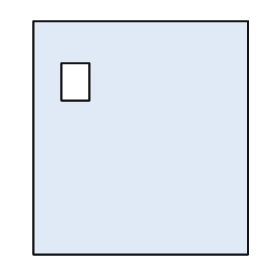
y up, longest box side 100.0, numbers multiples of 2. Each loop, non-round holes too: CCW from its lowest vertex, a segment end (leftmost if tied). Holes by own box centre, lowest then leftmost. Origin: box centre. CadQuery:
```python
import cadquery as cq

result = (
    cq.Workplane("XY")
    .moveTo(-46.0, -50.0)
    .lineTo(46.0, -50.0)
    .lineTo(46.0, 50.0)
    .lineTo(-46.0, 50.0)
    .close()
    .moveTo(-34.0, 16.0)
    .lineTo(-22.0, 16.0)
    .lineTo(-22.0, 32.0)
    .lineTo(-34.0, 32.0)
    .close()
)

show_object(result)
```